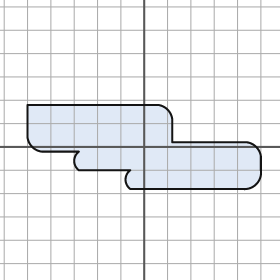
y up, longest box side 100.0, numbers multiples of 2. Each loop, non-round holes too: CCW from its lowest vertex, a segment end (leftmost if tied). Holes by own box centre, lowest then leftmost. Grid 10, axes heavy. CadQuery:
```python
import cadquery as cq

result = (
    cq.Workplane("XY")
    .moveTo(-6.0, -18.0)
    .lineTo(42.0, -18.0)
    .threePointArc((48.0, -16.0), (50.0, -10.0))
    .lineTo(50.0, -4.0)
    .threePointArc((48.0, 0.0), (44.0, 2.0))
    .lineTo(12.0, 2.0)
    .lineTo(12.0, 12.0)
    .threePointArc((10.0, 16.0), (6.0, 18.0))
    .lineTo(-50.0, 18.0)
    .lineTo(-50.0, 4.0)
    .threePointArc((-48.0, 0.0), (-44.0, -2.0))
    .lineTo(-28.0, -2.0)
    .threePointArc((-30.0, -6.0), (-28.0, -10.0))
    .lineTo(-6.0, -10.0)
    .threePointArc((-8.0, -14.0), (-6.0, -18.0))
    .close()
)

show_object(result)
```